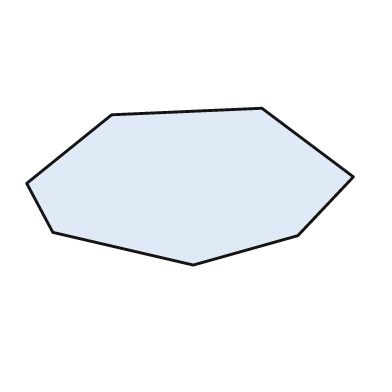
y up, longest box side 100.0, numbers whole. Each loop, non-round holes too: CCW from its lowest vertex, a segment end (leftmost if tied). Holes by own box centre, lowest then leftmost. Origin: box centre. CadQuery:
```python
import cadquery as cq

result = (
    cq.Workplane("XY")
    .moveTo(1.0, -24.0)
    .lineTo(33.0, -15.0)
    .lineTo(50.0, 3.0)
    .lineTo(22.0, 24.0)
    .lineTo(-24.0, 22.0)
    .lineTo(-50.0, 1.0)
    .lineTo(-42.0, -14.0)
    .close()
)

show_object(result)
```